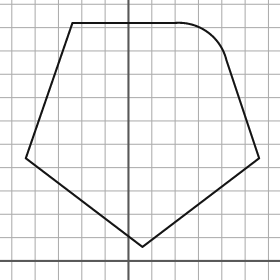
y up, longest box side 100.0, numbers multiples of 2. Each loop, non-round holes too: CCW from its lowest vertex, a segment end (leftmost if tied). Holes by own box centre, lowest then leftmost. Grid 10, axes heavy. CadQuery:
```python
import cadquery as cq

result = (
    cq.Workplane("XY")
    .moveTo(6.0, 6.0)
    .lineTo(56.0, 44.0)
    .lineTo(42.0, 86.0)
    .threePointArc((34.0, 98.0), (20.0, 102.0))
    .lineTo(-24.0, 102.0)
    .lineTo(-44.0, 44.0)
    .close()
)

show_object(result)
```